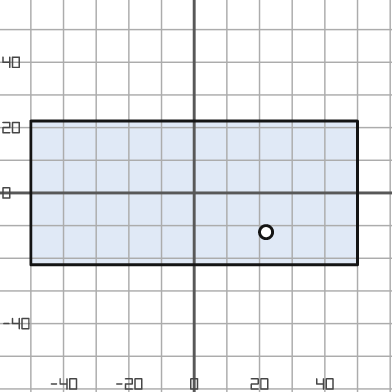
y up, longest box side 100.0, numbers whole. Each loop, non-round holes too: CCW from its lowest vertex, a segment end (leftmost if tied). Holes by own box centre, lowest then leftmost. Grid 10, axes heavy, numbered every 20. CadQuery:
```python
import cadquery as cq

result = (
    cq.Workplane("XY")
    .moveTo(-50.0, -22.0)
    .lineTo(50.0, -22.0)
    .lineTo(50.0, 22.0)
    .lineTo(-50.0, 22.0)
    .close()
    .moveTo(22.0, -12.0)
    .circle(2.0)
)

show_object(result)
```